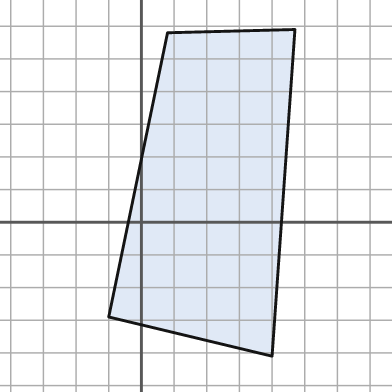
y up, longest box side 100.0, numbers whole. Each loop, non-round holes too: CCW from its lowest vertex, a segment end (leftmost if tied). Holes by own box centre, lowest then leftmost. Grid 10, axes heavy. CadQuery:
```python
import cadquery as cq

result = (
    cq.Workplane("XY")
    .moveTo(40.0, -41.0)
    .lineTo(47.0, 59.0)
    .lineTo(8.0, 58.0)
    .lineTo(-10.0, -29.0)
    .close()
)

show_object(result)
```